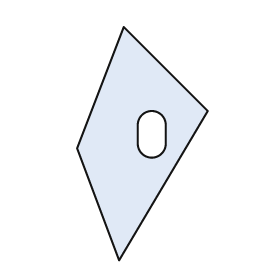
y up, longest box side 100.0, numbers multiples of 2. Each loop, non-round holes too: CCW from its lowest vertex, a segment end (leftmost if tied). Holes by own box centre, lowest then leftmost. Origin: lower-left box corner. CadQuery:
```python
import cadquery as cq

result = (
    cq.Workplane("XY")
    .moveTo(18.0, 0.0)
    .lineTo(56.0, 64.0)
    .lineTo(20.0, 100.0)
    .lineTo(0.0, 48.0)
    .close()
    .moveTo(26.0, 50.0)
    .threePointArc((32.0, 44.0), (38.0, 50.0))
    .lineTo(38.0, 58.0)
    .threePointArc((32.0, 64.0), (26.0, 58.0))
    .close()
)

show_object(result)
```